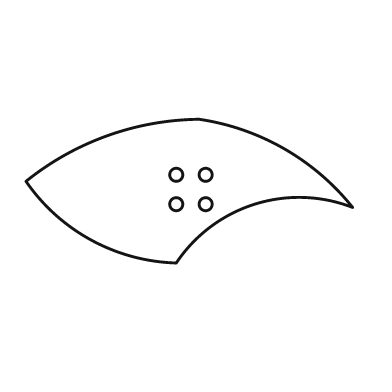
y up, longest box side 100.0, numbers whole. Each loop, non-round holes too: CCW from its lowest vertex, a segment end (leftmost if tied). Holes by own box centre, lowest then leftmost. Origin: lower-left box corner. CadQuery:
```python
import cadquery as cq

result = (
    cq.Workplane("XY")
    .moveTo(46.0, 0.0)
    .threePointArc((70.0, 18.0), (100.0, 17.0))
    .threePointArc((79.0, 35.0), (53.0, 44.0))
    .threePointArc((25.0, 39.0), (0.0, 25.0))
    .threePointArc((20.0, 7.0), (46.0, 0.0))
    .close()
    .moveTo(46.0, 18.0)
    .circle(2.0)
    .moveTo(55.0, 18.0)
    .circle(2.0)
    .moveTo(46.0, 27.0)
    .circle(2.0)
    .moveTo(55.0, 27.0)
    .circle(2.0)
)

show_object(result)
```